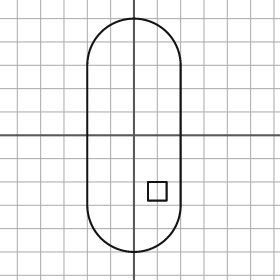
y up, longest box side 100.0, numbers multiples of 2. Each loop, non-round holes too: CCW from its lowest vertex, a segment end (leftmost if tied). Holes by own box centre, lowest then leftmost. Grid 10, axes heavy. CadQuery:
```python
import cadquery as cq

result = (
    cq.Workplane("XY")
    .moveTo(-20.0, -30.0)
    .threePointArc((0.0, -50.0), (20.0, -30.0))
    .lineTo(20.0, 30.0)
    .threePointArc((0.0, 50.0), (-20.0, 30.0))
    .close()
    .moveTo(6.0, -28.0)
    .lineTo(14.0, -28.0)
    .lineTo(14.0, -20.0)
    .lineTo(6.0, -20.0)
    .close()
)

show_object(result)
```